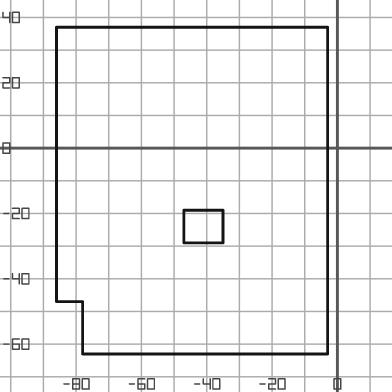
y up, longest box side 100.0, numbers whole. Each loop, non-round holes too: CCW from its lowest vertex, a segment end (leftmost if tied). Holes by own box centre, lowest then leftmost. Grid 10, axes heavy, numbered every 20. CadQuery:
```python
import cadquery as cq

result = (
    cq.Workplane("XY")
    .moveTo(-78.0, -63.0)
    .lineTo(-3.0, -63.0)
    .lineTo(-3.0, 37.0)
    .lineTo(-86.0, 37.0)
    .lineTo(-86.0, -47.0)
    .lineTo(-78.0, -47.0)
    .close()
    .moveTo(-47.0, -29.0)
    .lineTo(-35.0, -29.0)
    .lineTo(-35.0, -19.0)
    .lineTo(-47.0, -19.0)
    .close()
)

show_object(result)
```